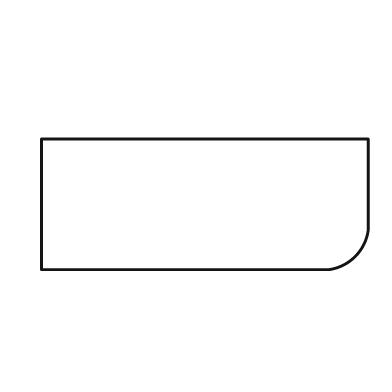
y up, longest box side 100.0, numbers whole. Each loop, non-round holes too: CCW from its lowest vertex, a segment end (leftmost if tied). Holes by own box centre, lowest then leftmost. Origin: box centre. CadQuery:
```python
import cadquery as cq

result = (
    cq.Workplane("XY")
    .moveTo(-50.0, -20.0)
    .lineTo(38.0, -20.0)
    .threePointArc((46.0, -16.0), (50.0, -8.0))
    .lineTo(50.0, 20.0)
    .lineTo(-50.0, 20.0)
    .close()
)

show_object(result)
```